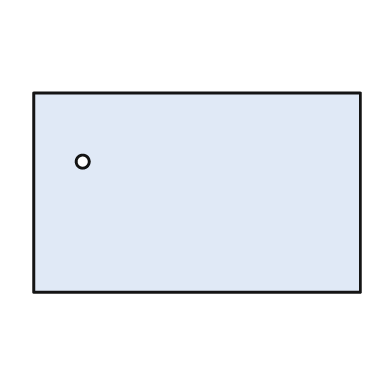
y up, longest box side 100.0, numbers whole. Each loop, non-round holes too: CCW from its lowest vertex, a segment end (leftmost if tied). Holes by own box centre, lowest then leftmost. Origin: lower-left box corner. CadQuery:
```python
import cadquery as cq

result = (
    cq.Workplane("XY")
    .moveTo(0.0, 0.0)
    .lineTo(100.0, 0.0)
    .lineTo(100.0, 61.0)
    .lineTo(0.0, 61.0)
    .close()
    .moveTo(15.0, 40.0)
    .circle(2.0)
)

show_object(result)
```